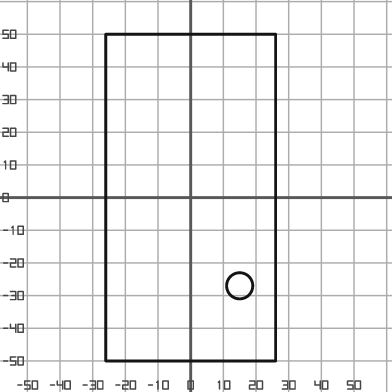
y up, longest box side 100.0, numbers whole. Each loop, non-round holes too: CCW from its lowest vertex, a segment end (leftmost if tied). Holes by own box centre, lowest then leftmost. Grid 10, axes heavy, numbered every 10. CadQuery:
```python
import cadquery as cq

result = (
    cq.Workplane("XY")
    .moveTo(-26.0, -50.0)
    .lineTo(26.0, -50.0)
    .lineTo(26.0, 50.0)
    .lineTo(-26.0, 50.0)
    .close()
    .moveTo(15.0, -27.0)
    .circle(4.0)
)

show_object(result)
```